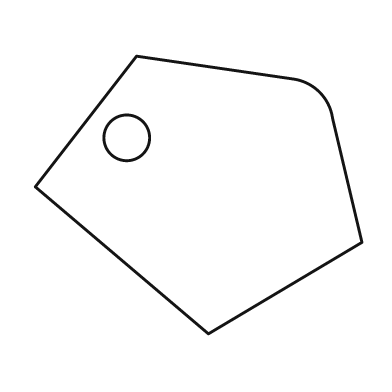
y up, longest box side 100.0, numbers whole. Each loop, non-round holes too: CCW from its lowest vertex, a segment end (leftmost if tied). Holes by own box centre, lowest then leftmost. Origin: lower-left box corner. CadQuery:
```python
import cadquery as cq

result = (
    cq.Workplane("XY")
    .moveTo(53.0, 0.0)
    .lineTo(100.0, 28.0)
    .lineTo(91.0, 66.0)
    .threePointArc((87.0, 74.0), (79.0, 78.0))
    .lineTo(31.0, 85.0)
    .lineTo(0.0, 45.0)
    .close()
    .moveTo(28.0, 60.0)
    .circle(7.0)
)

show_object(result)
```